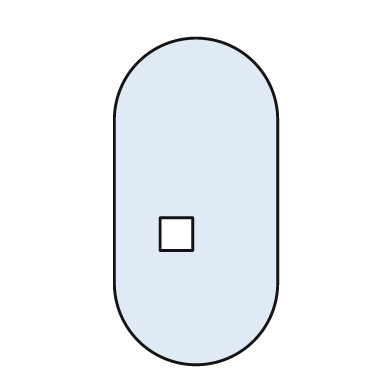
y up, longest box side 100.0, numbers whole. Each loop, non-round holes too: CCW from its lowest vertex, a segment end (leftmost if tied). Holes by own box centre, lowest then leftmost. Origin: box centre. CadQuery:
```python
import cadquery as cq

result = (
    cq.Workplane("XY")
    .moveTo(-25.0, -25.0)
    .threePointArc((0.0, -50.0), (25.0, -25.0))
    .lineTo(25.0, 25.0)
    .threePointArc((0.0, 50.0), (-25.0, 25.0))
    .close()
    .moveTo(-11.0, -15.0)
    .lineTo(-1.0, -15.0)
    .lineTo(-1.0, -5.0)
    .lineTo(-11.0, -5.0)
    .close()
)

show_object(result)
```